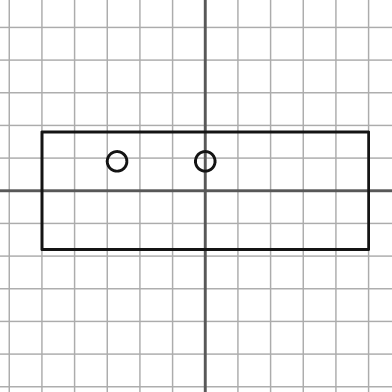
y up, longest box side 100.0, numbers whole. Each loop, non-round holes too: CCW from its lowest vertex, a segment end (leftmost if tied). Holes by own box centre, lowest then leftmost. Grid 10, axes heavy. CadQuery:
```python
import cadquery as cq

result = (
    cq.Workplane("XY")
    .moveTo(-50.0, -18.0)
    .lineTo(50.0, -18.0)
    .lineTo(50.0, 18.0)
    .lineTo(-50.0, 18.0)
    .close()
    .moveTo(-27.0, 9.0)
    .circle(3.0)
    .moveTo(0.0, 9.0)
    .circle(3.0)
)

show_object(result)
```